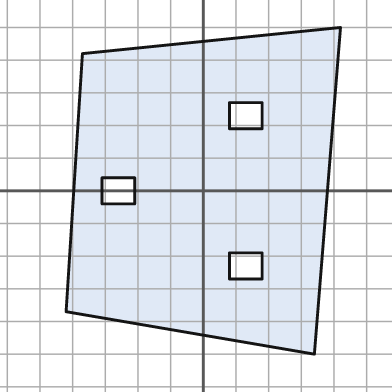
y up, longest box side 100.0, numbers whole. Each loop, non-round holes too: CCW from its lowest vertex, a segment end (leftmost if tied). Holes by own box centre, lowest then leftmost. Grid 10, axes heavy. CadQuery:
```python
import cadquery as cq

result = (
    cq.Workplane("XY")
    .moveTo(34.0, -50.0)
    .lineTo(42.0, 50.0)
    .lineTo(-37.0, 42.0)
    .lineTo(-42.0, -37.0)
    .close()
    .moveTo(8.0, -27.0)
    .lineTo(18.0, -27.0)
    .lineTo(18.0, -19.0)
    .lineTo(8.0, -19.0)
    .close()
    .moveTo(-31.0, -4.0)
    .lineTo(-21.0, -4.0)
    .lineTo(-21.0, 4.0)
    .lineTo(-31.0, 4.0)
    .close()
    .moveTo(8.0, 19.0)
    .lineTo(18.0, 19.0)
    .lineTo(18.0, 27.0)
    .lineTo(8.0, 27.0)
    .close()
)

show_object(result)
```